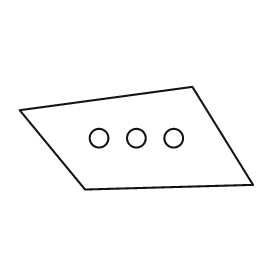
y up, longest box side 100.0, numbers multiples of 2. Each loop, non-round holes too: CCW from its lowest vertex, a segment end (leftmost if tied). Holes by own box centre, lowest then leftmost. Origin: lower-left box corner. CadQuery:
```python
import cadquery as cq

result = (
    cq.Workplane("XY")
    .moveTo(28.0, 0.0)
    .lineTo(100.0, 2.0)
    .lineTo(74.0, 44.0)
    .lineTo(0.0, 34.0)
    .close()
    .moveTo(34.0, 22.0)
    .circle(4.0)
    .moveTo(50.0, 22.0)
    .circle(4.0)
    .moveTo(66.0, 22.0)
    .circle(4.0)
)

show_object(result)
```